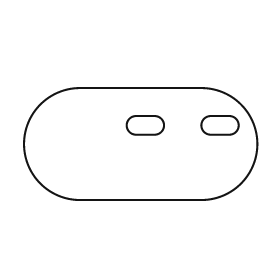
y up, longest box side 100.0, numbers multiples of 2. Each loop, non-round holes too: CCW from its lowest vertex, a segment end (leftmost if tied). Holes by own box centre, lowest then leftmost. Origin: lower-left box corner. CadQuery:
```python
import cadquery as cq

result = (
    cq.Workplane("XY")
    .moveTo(24.0, 0.0)
    .lineTo(76.0, 0.0)
    .threePointArc((100.0, 24.0), (76.0, 48.0))
    .lineTo(24.0, 48.0)
    .threePointArc((0.0, 24.0), (24.0, 0.0))
    .close()
    .moveTo(48.0, 28.0)
    .lineTo(56.0, 28.0)
    .threePointArc((60.0, 32.0), (56.0, 36.0))
    .lineTo(48.0, 36.0)
    .threePointArc((44.0, 32.0), (48.0, 28.0))
    .close()
    .moveTo(80.0, 28.0)
    .lineTo(88.0, 28.0)
    .threePointArc((92.0, 32.0), (88.0, 36.0))
    .lineTo(80.0, 36.0)
    .threePointArc((76.0, 32.0), (80.0, 28.0))
    .close()
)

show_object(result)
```